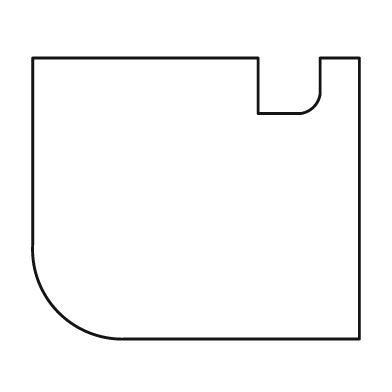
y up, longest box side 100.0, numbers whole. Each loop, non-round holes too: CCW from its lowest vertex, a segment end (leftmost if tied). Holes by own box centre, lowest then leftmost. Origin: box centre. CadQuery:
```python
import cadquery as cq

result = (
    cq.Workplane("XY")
    .moveTo(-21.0, -43.0)
    .lineTo(50.0, -43.0)
    .lineTo(50.0, 43.0)
    .lineTo(38.0, 43.0)
    .lineTo(38.0, 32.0)
    .threePointArc((36.0, 28.0), (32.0, 26.0))
    .lineTo(19.0, 26.0)
    .lineTo(19.0, 43.0)
    .lineTo(-50.0, 43.0)
    .lineTo(-50.0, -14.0)
    .threePointArc((-42.0, -35.0), (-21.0, -43.0))
    .close()
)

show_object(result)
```